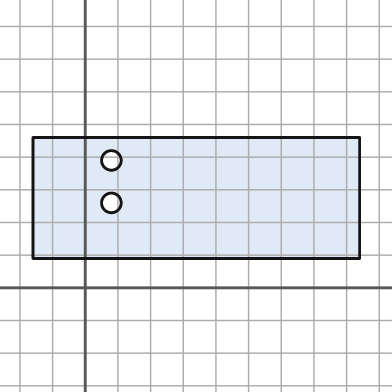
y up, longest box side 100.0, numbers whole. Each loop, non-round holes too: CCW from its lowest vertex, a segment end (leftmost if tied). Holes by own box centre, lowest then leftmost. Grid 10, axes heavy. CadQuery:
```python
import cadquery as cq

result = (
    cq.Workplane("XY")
    .moveTo(-16.0, 9.0)
    .lineTo(84.0, 9.0)
    .lineTo(84.0, 46.0)
    .lineTo(-16.0, 46.0)
    .close()
    .moveTo(8.0, 26.0)
    .circle(3.0)
    .moveTo(8.0, 39.0)
    .circle(3.0)
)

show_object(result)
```